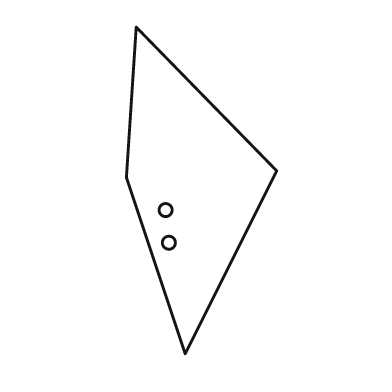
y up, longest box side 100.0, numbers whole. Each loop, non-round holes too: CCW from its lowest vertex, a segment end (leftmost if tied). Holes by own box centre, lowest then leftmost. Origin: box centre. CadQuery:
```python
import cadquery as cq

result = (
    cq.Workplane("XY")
    .moveTo(-5.0, -50.0)
    .lineTo(23.0, 6.0)
    .lineTo(-20.0, 50.0)
    .lineTo(-23.0, 4.0)
    .close()
    .moveTo(-10.0, -16.0)
    .circle(2.0)
    .moveTo(-11.0, -6.0)
    .circle(2.0)
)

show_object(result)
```